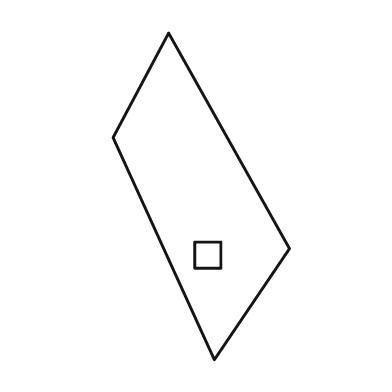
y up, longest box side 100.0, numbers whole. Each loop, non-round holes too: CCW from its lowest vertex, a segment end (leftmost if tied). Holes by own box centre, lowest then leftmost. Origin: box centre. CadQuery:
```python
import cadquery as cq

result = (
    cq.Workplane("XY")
    .moveTo(4.0, -50.0)
    .lineTo(27.0, -16.0)
    .lineTo(-10.0, 50.0)
    .lineTo(-27.0, 18.0)
    .close()
    .moveTo(-2.0, -22.0)
    .lineTo(6.0, -22.0)
    .lineTo(6.0, -14.0)
    .lineTo(-2.0, -14.0)
    .close()
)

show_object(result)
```